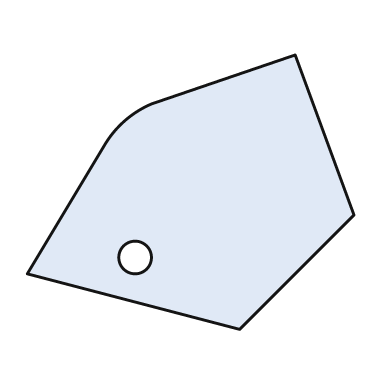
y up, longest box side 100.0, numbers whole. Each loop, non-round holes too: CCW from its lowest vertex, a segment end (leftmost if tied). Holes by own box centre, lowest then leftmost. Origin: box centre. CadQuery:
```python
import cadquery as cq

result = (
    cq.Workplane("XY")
    .moveTo(15.0, -42.0)
    .lineTo(50.0, -7.0)
    .lineTo(32.0, 42.0)
    .lineTo(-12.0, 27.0)
    .threePointArc((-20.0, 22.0), (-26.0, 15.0))
    .lineTo(-50.0, -25.0)
    .close()
    .moveTo(-17.0, -20.0)
    .circle(5.0)
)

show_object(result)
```